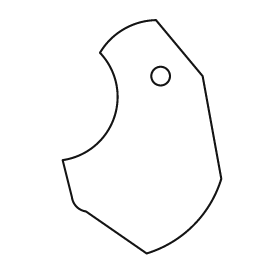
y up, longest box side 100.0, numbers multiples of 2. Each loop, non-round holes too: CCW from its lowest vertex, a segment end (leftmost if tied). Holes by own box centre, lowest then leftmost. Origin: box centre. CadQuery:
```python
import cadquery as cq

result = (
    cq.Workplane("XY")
    .moveTo(2.0, -50.0)
    .threePointArc((22.0, -38.0), (34.0, -18.0))
    .lineTo(26.0, 26.0)
    .lineTo(6.0, 50.0)
    .threePointArc((-8.0, 46.0), (-18.0, 36.0))
    .threePointArc((-12.0, 8.0), (-34.0, -10.0))
    .lineTo(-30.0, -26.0)
    .threePointArc((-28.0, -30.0), (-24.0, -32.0))
    .close()
    .moveTo(8.0, 26.0)
    .circle(4.0)
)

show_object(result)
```